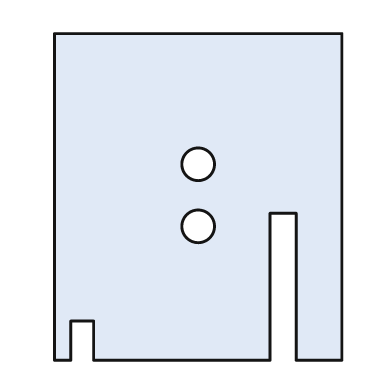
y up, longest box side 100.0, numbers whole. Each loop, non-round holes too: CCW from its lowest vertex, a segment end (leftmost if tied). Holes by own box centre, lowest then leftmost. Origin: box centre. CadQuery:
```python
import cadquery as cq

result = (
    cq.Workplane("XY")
    .moveTo(-44.0, -50.0)
    .lineTo(-39.0, -50.0)
    .lineTo(-39.0, -38.0)
    .lineTo(-32.0, -38.0)
    .lineTo(-32.0, -50.0)
    .lineTo(22.0, -50.0)
    .lineTo(22.0, -5.0)
    .lineTo(30.0, -5.0)
    .lineTo(30.0, -50.0)
    .lineTo(44.0, -50.0)
    .lineTo(44.0, 50.0)
    .lineTo(-44.0, 50.0)
    .close()
    .moveTo(0.0, -9.0)
    .circle(5.0)
    .moveTo(0.0, 10.0)
    .circle(5.0)
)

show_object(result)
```